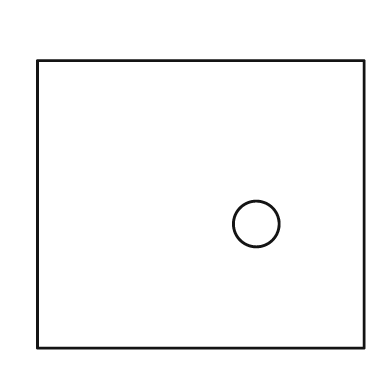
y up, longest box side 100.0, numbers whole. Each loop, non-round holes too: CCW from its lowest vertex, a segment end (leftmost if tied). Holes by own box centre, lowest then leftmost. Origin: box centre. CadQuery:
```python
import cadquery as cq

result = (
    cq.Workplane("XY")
    .moveTo(-50.0, -44.0)
    .lineTo(50.0, -44.0)
    .lineTo(50.0, 44.0)
    .lineTo(-50.0, 44.0)
    .close()
    .moveTo(17.0, -6.0)
    .circle(7.0)
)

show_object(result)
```